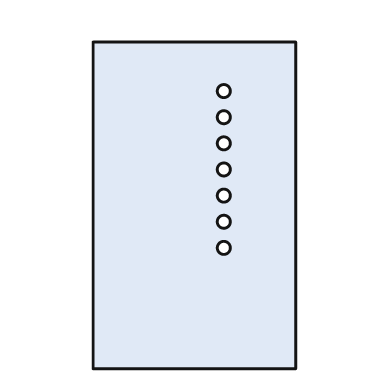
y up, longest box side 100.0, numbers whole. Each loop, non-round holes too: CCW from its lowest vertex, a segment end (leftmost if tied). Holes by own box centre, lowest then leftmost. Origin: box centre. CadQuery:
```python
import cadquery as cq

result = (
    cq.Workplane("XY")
    .moveTo(-31.0, -50.0)
    .lineTo(31.0, -50.0)
    .lineTo(31.0, 50.0)
    .lineTo(-31.0, 50.0)
    .close()
    .moveTo(9.0, -13.0)
    .circle(2.0)
    .moveTo(9.0, -5.0)
    .circle(2.0)
    .moveTo(9.0, 3.0)
    .circle(2.0)
    .moveTo(9.0, 11.0)
    .circle(2.0)
    .moveTo(9.0, 19.0)
    .circle(2.0)
    .moveTo(9.0, 27.0)
    .circle(2.0)
    .moveTo(9.0, 35.0)
    .circle(2.0)
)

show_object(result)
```